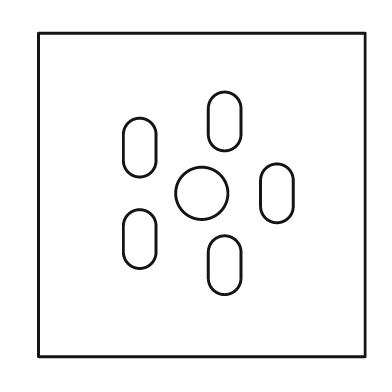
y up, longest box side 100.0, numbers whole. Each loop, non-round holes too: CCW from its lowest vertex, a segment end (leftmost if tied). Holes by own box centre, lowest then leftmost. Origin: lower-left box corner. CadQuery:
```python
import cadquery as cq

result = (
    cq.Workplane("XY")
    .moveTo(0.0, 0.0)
    .lineTo(100.0, 0.0)
    .lineTo(100.0, 99.0)
    .lineTo(0.0, 99.0)
    .close()
    .moveTo(52.0, 24.0)
    .threePointArc((57.0, 19.0), (62.0, 24.0))
    .lineTo(62.0, 32.0)
    .threePointArc((57.0, 37.0), (52.0, 32.0))
    .close()
    .moveTo(26.0, 32.0)
    .threePointArc((31.0, 27.0), (36.0, 32.0))
    .lineTo(36.0, 40.0)
    .threePointArc((31.0, 45.0), (26.0, 40.0))
    .close()
    .moveTo(50.0, 50.0)
    .circle(8.0)
    .moveTo(68.0, 46.0)
    .threePointArc((73.0, 41.0), (78.0, 46.0))
    .lineTo(78.0, 54.0)
    .threePointArc((73.0, 59.0), (68.0, 54.0))
    .close()
    .moveTo(26.0, 60.0)
    .threePointArc((31.0, 55.0), (36.0, 60.0))
    .lineTo(36.0, 68.0)
    .threePointArc((31.0, 73.0), (26.0, 68.0))
    .close()
    .moveTo(52.0, 68.0)
    .threePointArc((57.0, 63.0), (62.0, 68.0))
    .lineTo(62.0, 76.0)
    .threePointArc((57.0, 81.0), (52.0, 76.0))
    .close()
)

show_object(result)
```